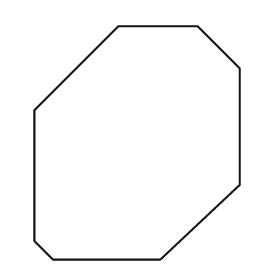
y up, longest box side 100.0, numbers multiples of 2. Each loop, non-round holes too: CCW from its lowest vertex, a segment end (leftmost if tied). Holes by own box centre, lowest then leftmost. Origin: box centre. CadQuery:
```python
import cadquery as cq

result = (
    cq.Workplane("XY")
    .moveTo(-36.0, -50.0)
    .lineTo(10.0, -50.0)
    .lineTo(44.0, -18.0)
    .lineTo(44.0, 32.0)
    .lineTo(26.0, 50.0)
    .lineTo(-8.0, 50.0)
    .lineTo(-44.0, 14.0)
    .lineTo(-44.0, -42.0)
    .close()
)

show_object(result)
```